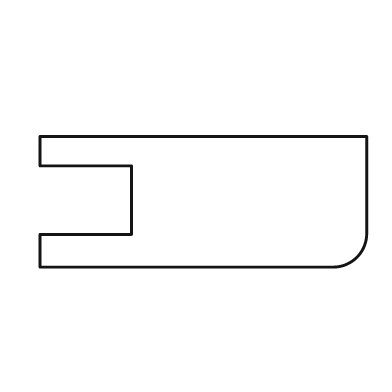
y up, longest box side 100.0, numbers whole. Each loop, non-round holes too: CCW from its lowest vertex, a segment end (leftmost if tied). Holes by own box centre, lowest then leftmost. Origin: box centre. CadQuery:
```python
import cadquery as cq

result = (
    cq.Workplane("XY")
    .moveTo(-50.0, -20.0)
    .lineTo(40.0, -20.0)
    .threePointArc((47.0, -17.0), (50.0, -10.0))
    .lineTo(50.0, 20.0)
    .lineTo(-50.0, 20.0)
    .lineTo(-50.0, 11.0)
    .lineTo(-22.0, 11.0)
    .lineTo(-22.0, -10.0)
    .lineTo(-50.0, -10.0)
    .close()
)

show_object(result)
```